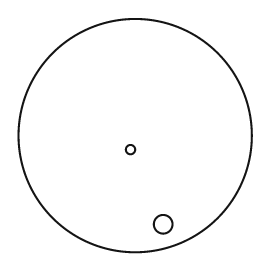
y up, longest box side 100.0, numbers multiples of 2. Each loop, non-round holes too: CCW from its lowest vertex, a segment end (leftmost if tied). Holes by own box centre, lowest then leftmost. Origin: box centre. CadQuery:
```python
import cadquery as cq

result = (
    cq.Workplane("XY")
    .moveTo(0.0, 0.0)
    .circle(50.0)
    .moveTo(12.0, -38.0)
    .circle(4.0)
    .moveTo(-2.0, -6.0)
    .circle(2.0)
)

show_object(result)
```